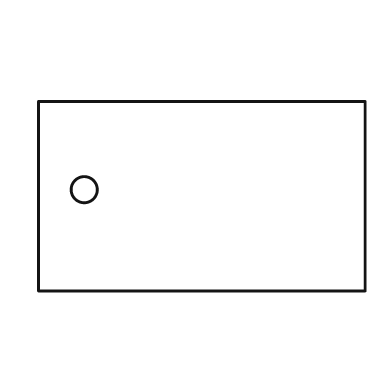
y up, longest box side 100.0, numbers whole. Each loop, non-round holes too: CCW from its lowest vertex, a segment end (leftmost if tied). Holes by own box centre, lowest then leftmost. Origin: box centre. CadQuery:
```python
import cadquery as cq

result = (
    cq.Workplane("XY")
    .moveTo(-50.0, -29.0)
    .lineTo(50.0, -29.0)
    .lineTo(50.0, 29.0)
    .lineTo(-50.0, 29.0)
    .close()
    .moveTo(-36.0, 2.0)
    .circle(4.0)
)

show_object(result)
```